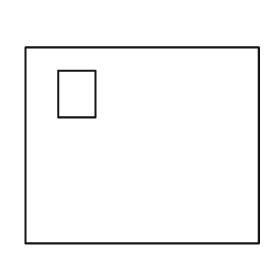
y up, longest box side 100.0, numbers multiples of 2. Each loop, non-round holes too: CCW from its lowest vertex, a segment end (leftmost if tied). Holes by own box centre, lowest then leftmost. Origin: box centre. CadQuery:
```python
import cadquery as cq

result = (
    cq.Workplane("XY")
    .moveTo(-50.0, -42.0)
    .lineTo(50.0, -42.0)
    .lineTo(50.0, 42.0)
    .lineTo(-50.0, 42.0)
    .close()
    .moveTo(-36.0, 12.0)
    .lineTo(-20.0, 12.0)
    .lineTo(-20.0, 32.0)
    .lineTo(-36.0, 32.0)
    .close()
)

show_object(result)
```